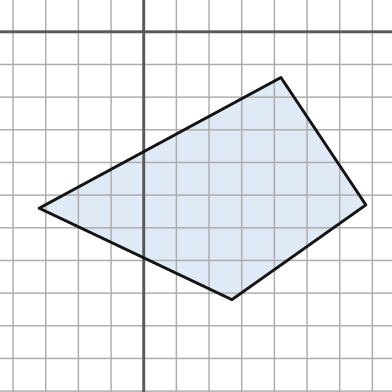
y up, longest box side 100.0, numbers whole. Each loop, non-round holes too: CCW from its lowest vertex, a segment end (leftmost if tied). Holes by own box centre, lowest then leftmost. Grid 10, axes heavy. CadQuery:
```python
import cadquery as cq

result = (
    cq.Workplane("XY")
    .moveTo(27.0, -82.0)
    .lineTo(68.0, -53.0)
    .lineTo(42.0, -14.0)
    .lineTo(-32.0, -54.0)
    .close()
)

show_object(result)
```